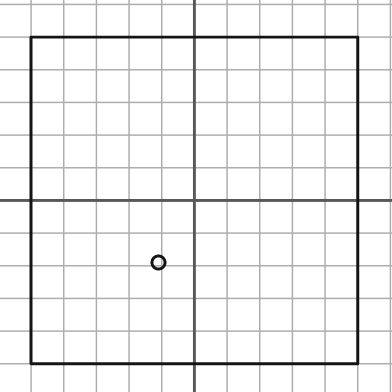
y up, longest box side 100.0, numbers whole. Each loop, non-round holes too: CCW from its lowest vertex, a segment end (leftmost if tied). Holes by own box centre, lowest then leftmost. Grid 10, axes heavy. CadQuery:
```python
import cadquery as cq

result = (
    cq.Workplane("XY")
    .moveTo(-50.0, -50.0)
    .lineTo(50.0, -50.0)
    .lineTo(50.0, 50.0)
    .lineTo(-50.0, 50.0)
    .close()
    .moveTo(-11.0, -19.0)
    .circle(2.0)
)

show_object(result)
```